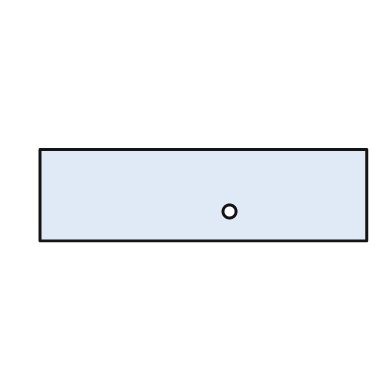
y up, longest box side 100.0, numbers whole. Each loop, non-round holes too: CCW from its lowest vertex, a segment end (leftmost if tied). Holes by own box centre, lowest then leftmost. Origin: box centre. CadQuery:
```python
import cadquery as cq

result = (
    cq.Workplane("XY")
    .moveTo(-50.0, -14.0)
    .lineTo(50.0, -14.0)
    .lineTo(50.0, 14.0)
    .lineTo(-50.0, 14.0)
    .close()
    .moveTo(8.0, -5.0)
    .circle(2.0)
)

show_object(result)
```